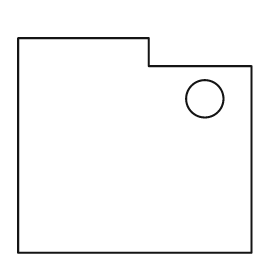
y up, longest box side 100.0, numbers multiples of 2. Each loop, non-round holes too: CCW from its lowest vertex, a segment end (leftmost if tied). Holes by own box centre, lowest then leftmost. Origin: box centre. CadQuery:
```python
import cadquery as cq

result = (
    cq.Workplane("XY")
    .moveTo(-50.0, -46.0)
    .lineTo(50.0, -46.0)
    .lineTo(50.0, 34.0)
    .lineTo(6.0, 34.0)
    .lineTo(6.0, 46.0)
    .lineTo(-50.0, 46.0)
    .close()
    .moveTo(30.0, 20.0)
    .circle(8.0)
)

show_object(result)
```